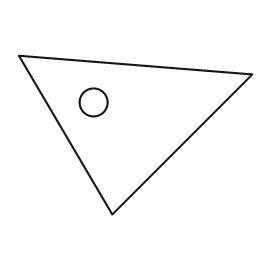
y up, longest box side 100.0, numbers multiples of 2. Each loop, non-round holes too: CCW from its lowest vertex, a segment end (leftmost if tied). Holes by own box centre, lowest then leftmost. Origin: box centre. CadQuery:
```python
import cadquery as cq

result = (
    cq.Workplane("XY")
    .moveTo(-10.0, -34.0)
    .lineTo(50.0, 26.0)
    .lineTo(-50.0, 34.0)
    .close()
    .moveTo(-18.0, 14.0)
    .circle(6.0)
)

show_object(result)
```